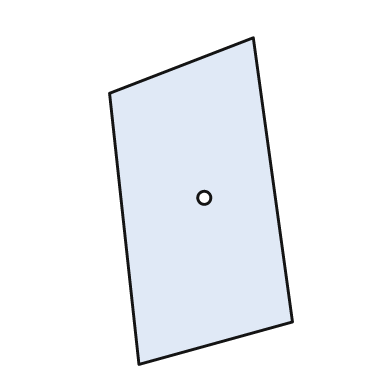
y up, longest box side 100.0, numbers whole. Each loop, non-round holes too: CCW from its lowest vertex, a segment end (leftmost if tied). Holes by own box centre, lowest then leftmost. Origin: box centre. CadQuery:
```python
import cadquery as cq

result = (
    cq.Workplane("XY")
    .moveTo(-19.0, -50.0)
    .lineTo(28.0, -37.0)
    .lineTo(16.0, 50.0)
    .lineTo(-28.0, 33.0)
    .close()
    .moveTo(1.0, 1.0)
    .circle(2.0)
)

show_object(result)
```